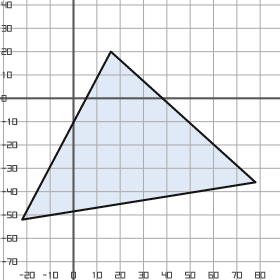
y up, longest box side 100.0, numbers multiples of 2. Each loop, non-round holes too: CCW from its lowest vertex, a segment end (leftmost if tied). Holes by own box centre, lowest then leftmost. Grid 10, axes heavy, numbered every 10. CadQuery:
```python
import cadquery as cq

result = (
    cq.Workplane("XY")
    .moveTo(-22.0, -52.0)
    .lineTo(78.0, -36.0)
    .lineTo(16.0, 20.0)
    .close()
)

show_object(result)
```